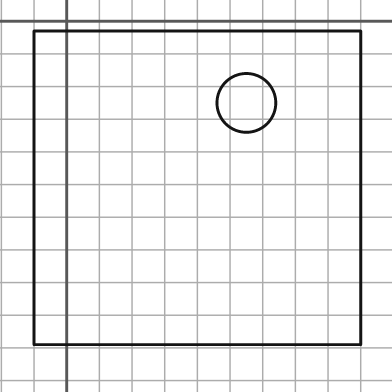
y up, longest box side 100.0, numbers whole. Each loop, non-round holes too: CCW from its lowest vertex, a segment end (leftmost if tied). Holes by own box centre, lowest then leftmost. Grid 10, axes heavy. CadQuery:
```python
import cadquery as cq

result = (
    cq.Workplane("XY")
    .moveTo(-10.0, -99.0)
    .lineTo(90.0, -99.0)
    .lineTo(90.0, -3.0)
    .lineTo(-10.0, -3.0)
    .close()
    .moveTo(55.0, -25.0)
    .circle(9.0)
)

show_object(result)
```